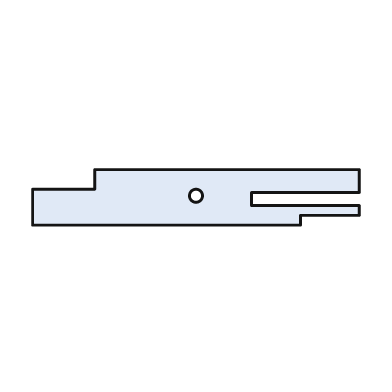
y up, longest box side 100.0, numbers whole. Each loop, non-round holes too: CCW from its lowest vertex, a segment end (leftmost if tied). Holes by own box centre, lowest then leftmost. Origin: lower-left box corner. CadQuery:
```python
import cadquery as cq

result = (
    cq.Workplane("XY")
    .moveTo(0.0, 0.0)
    .lineTo(82.0, 0.0)
    .lineTo(82.0, 3.0)
    .lineTo(100.0, 3.0)
    .lineTo(100.0, 6.0)
    .lineTo(67.0, 6.0)
    .lineTo(67.0, 10.0)
    .lineTo(100.0, 10.0)
    .lineTo(100.0, 17.0)
    .lineTo(19.0, 17.0)
    .lineTo(19.0, 11.0)
    .lineTo(0.0, 11.0)
    .close()
    .moveTo(50.0, 9.0)
    .circle(2.0)
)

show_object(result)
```